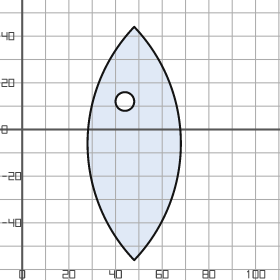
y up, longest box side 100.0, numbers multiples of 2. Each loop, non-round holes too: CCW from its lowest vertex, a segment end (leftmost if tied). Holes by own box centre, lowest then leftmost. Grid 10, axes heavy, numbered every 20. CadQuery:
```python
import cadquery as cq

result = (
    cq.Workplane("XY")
    .moveTo(48.0, -56.0)
    .threePointArc((68.0, -6.0), (48.0, 44.0))
    .threePointArc((28.0, -6.0), (48.0, -56.0))
    .close()
    .moveTo(44.0, 12.0)
    .circle(4.0)
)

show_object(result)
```